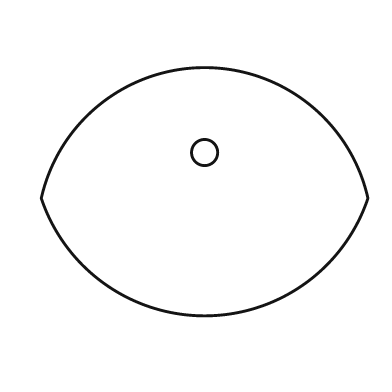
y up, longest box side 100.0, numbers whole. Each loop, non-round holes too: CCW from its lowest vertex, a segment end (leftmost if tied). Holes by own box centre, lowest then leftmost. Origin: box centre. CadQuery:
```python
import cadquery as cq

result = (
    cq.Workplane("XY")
    .moveTo(-50.0, -2.0)
    .threePointArc((0.0, -38.0), (50.0, -2.0))
    .threePointArc((0.0, 38.0), (-50.0, -2.0))
    .close()
    .moveTo(0.0, 12.0)
    .circle(4.0)
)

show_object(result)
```